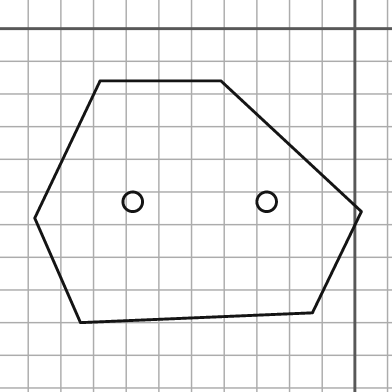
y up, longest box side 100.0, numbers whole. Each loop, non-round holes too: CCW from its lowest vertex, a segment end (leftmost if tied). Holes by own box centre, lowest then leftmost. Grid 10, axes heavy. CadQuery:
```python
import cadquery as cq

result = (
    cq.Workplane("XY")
    .moveTo(-84.0, -90.0)
    .lineTo(-13.0, -87.0)
    .lineTo(2.0, -56.0)
    .lineTo(-41.0, -16.0)
    .lineTo(-78.0, -16.0)
    .lineTo(-98.0, -58.0)
    .close()
    .moveTo(-68.0, -53.0)
    .circle(3.0)
    .moveTo(-27.0, -53.0)
    .circle(3.0)
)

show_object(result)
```